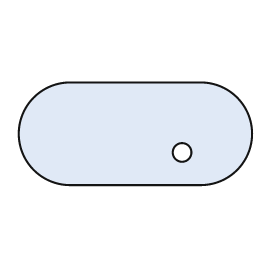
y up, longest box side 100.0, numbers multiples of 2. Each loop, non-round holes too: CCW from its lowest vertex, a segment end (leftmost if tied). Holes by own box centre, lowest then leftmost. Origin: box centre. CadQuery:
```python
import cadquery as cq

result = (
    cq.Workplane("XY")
    .moveTo(-28.0, -22.0)
    .lineTo(28.0, -22.0)
    .threePointArc((50.0, 0.0), (28.0, 22.0))
    .lineTo(-28.0, 22.0)
    .threePointArc((-50.0, 0.0), (-28.0, -22.0))
    .close()
    .moveTo(20.0, -8.0)
    .circle(4.0)
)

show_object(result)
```